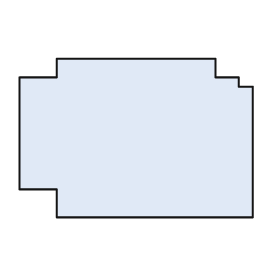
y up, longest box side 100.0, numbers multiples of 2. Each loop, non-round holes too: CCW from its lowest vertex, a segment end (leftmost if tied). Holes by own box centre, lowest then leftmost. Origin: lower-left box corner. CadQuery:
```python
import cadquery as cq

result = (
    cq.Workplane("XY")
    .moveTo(16.0, 0.0)
    .lineTo(100.0, 0.0)
    .lineTo(100.0, 56.0)
    .lineTo(94.0, 56.0)
    .lineTo(94.0, 60.0)
    .lineTo(84.0, 60.0)
    .lineTo(84.0, 68.0)
    .lineTo(16.0, 68.0)
    .lineTo(16.0, 60.0)
    .lineTo(0.0, 60.0)
    .lineTo(0.0, 12.0)
    .lineTo(16.0, 12.0)
    .close()
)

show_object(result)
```